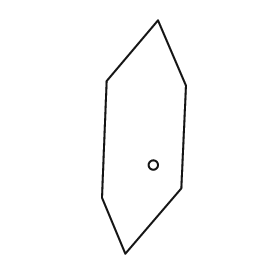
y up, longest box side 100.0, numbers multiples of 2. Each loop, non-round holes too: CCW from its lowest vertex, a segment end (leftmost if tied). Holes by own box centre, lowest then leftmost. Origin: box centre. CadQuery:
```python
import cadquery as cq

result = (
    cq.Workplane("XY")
    .moveTo(-8.0, -50.0)
    .lineTo(16.0, -22.0)
    .lineTo(18.0, 22.0)
    .lineTo(6.0, 50.0)
    .lineTo(-16.0, 24.0)
    .lineTo(-18.0, -26.0)
    .close()
    .moveTo(4.0, -12.0)
    .circle(2.0)
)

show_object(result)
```